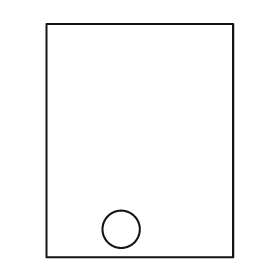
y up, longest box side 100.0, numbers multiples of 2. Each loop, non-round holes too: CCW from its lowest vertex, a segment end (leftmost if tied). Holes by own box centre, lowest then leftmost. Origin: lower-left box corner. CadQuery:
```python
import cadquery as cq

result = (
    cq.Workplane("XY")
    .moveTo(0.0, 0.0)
    .lineTo(80.0, 0.0)
    .lineTo(80.0, 100.0)
    .lineTo(0.0, 100.0)
    .close()
    .moveTo(32.0, 12.0)
    .circle(8.0)
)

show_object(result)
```